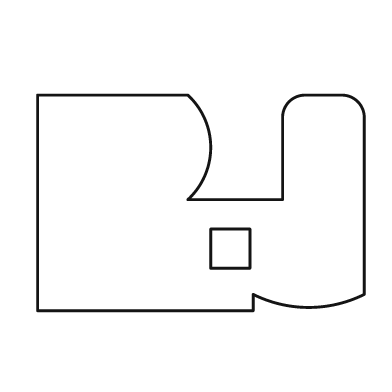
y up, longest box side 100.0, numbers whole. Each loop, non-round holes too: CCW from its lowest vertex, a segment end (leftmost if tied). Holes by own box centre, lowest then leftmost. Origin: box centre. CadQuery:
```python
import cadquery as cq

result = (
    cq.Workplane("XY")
    .moveTo(-50.0, -33.0)
    .lineTo(16.0, -33.0)
    .lineTo(16.0, -28.0)
    .threePointArc((33.0, -32.0), (50.0, -28.0))
    .lineTo(50.0, 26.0)
    .threePointArc((48.0, 31.0), (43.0, 33.0))
    .lineTo(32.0, 33.0)
    .threePointArc((27.0, 31.0), (25.0, 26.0))
    .lineTo(25.0, 1.0)
    .lineTo(-4.0, 1.0)
    .threePointArc((3.0, 17.0), (-4.0, 33.0))
    .lineTo(-50.0, 33.0)
    .close()
    .moveTo(3.0, -20.0)
    .lineTo(15.0, -20.0)
    .lineTo(15.0, -8.0)
    .lineTo(3.0, -8.0)
    .close()
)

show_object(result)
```